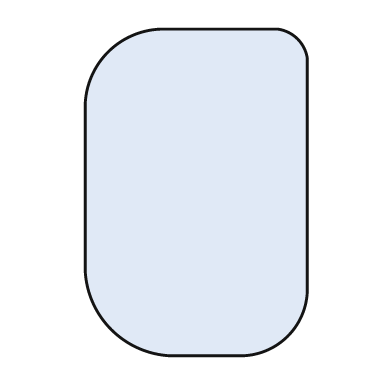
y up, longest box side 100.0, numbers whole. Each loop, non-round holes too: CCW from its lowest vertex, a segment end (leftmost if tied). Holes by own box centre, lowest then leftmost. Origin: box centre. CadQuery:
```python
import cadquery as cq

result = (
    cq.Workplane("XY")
    .moveTo(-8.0, -50.0)
    .lineTo(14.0, -50.0)
    .threePointArc((28.0, -44.0), (34.0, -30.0))
    .lineTo(34.0, 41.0)
    .threePointArc((31.0, 47.0), (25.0, 50.0))
    .lineTo(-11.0, 50.0)
    .threePointArc((-27.0, 43.0), (-34.0, 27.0))
    .lineTo(-34.0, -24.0)
    .threePointArc((-26.0, -42.0), (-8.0, -50.0))
    .close()
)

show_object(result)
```